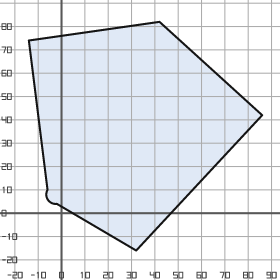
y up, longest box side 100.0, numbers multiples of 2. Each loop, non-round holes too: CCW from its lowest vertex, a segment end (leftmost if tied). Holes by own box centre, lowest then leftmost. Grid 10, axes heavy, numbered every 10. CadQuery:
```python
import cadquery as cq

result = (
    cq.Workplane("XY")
    .moveTo(32.0, -16.0)
    .lineTo(86.0, 42.0)
    .lineTo(42.0, 82.0)
    .lineTo(-14.0, 74.0)
    .lineTo(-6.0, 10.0)
    .threePointArc((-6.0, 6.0), (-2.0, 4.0))
    .close()
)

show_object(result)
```